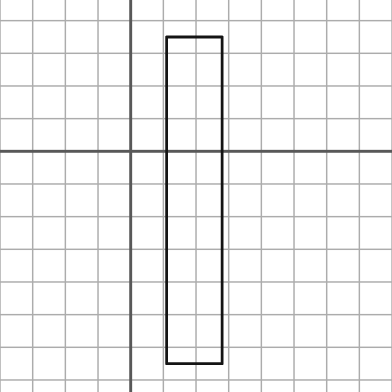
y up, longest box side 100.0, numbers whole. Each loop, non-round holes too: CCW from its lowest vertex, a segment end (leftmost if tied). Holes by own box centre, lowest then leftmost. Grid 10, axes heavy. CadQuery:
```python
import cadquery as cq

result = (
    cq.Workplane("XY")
    .moveTo(11.0, -65.0)
    .lineTo(28.0, -65.0)
    .lineTo(28.0, 35.0)
    .lineTo(11.0, 35.0)
    .close()
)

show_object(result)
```